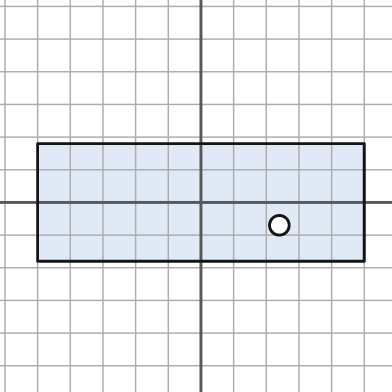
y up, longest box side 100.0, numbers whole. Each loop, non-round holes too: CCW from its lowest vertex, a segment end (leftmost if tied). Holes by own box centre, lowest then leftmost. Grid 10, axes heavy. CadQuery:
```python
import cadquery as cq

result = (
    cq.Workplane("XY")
    .moveTo(-50.0, -18.0)
    .lineTo(50.0, -18.0)
    .lineTo(50.0, 18.0)
    .lineTo(-50.0, 18.0)
    .close()
    .moveTo(24.0, -7.0)
    .circle(3.0)
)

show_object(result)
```